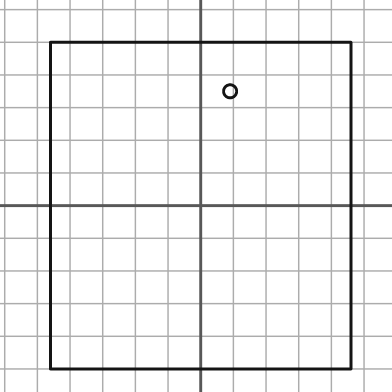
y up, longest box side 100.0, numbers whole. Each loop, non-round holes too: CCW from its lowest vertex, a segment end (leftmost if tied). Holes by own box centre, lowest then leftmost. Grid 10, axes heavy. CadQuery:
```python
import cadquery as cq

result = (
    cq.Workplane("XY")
    .moveTo(-46.0, -50.0)
    .lineTo(46.0, -50.0)
    .lineTo(46.0, 50.0)
    .lineTo(-46.0, 50.0)
    .close()
    .moveTo(9.0, 35.0)
    .circle(2.0)
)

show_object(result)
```